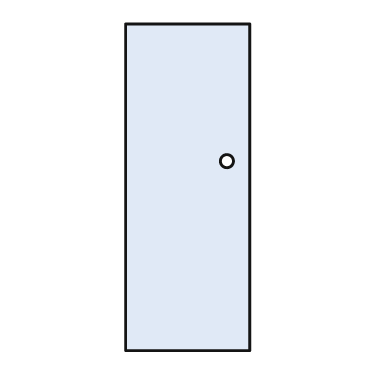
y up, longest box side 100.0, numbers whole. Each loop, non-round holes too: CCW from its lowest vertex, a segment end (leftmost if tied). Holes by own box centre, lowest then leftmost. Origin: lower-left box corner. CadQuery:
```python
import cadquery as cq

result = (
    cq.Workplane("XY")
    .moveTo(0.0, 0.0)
    .lineTo(38.0, 0.0)
    .lineTo(38.0, 100.0)
    .lineTo(0.0, 100.0)
    .close()
    .moveTo(31.0, 58.0)
    .circle(2.0)
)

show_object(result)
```